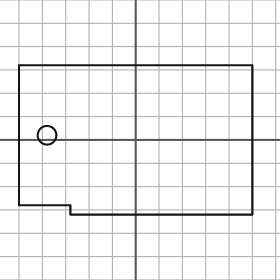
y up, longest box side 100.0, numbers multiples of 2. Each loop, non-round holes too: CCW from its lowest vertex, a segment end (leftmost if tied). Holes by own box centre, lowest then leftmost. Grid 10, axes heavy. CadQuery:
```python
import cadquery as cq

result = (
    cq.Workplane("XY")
    .moveTo(-28.0, -32.0)
    .lineTo(50.0, -32.0)
    .lineTo(50.0, 32.0)
    .lineTo(-50.0, 32.0)
    .lineTo(-50.0, -28.0)
    .lineTo(-28.0, -28.0)
    .close()
    .moveTo(-38.0, 2.0)
    .circle(4.0)
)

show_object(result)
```